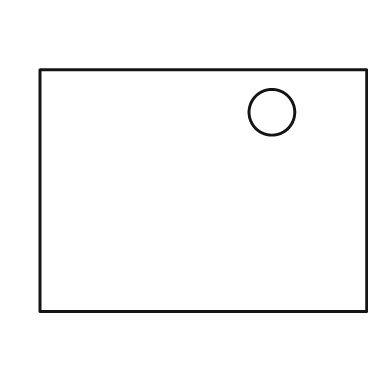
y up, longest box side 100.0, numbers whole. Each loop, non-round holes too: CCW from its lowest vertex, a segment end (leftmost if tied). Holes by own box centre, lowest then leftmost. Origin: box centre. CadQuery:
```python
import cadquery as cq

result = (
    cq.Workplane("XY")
    .moveTo(-50.0, -37.0)
    .lineTo(50.0, -37.0)
    .lineTo(50.0, 37.0)
    .lineTo(-50.0, 37.0)
    .close()
    .moveTo(21.0, 24.0)
    .circle(7.0)
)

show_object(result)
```